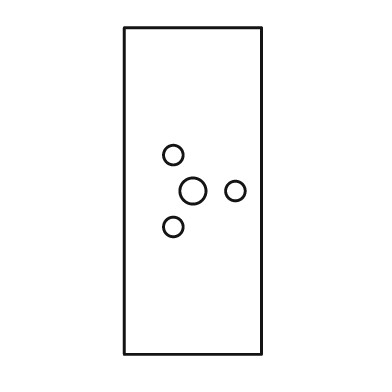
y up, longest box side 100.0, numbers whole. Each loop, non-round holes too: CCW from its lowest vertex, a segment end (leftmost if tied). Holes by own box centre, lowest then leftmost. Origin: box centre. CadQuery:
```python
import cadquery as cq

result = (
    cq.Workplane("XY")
    .moveTo(-21.0, -50.0)
    .lineTo(21.0, -50.0)
    .lineTo(21.0, 50.0)
    .lineTo(-21.0, 50.0)
    .close()
    .moveTo(-6.0, -11.0)
    .circle(3.0)
    .moveTo(0.0, 0.0)
    .circle(4.0)
    .moveTo(13.0, 0.0)
    .circle(3.0)
    .moveTo(-6.0, 11.0)
    .circle(3.0)
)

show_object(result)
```